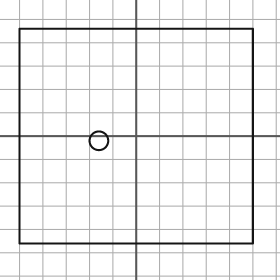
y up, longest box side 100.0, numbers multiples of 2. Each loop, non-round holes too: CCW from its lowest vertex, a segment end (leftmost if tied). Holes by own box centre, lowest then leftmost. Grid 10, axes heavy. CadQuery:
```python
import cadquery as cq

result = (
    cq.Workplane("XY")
    .moveTo(-50.0, -46.0)
    .lineTo(50.0, -46.0)
    .lineTo(50.0, 46.0)
    .lineTo(-50.0, 46.0)
    .close()
    .moveTo(-16.0, -2.0)
    .circle(4.0)
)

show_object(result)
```